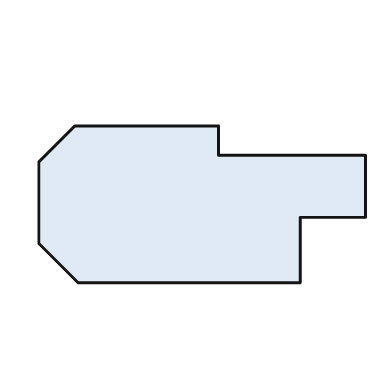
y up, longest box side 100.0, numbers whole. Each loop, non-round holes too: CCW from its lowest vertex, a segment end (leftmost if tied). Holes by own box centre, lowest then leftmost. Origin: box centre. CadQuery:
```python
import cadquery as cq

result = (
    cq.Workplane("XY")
    .moveTo(-38.0, -24.0)
    .lineTo(30.0, -24.0)
    .lineTo(30.0, -4.0)
    .lineTo(50.0, -4.0)
    .lineTo(50.0, 15.0)
    .lineTo(5.0, 15.0)
    .lineTo(5.0, 24.0)
    .lineTo(-39.0, 24.0)
    .lineTo(-50.0, 13.0)
    .lineTo(-50.0, -12.0)
    .close()
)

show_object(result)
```